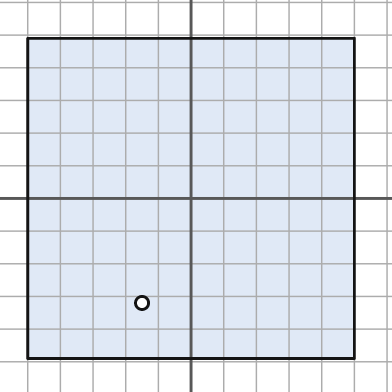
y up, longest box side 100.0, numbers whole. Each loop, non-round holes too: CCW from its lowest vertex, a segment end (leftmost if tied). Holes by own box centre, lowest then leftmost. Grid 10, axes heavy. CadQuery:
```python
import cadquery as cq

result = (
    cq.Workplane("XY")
    .moveTo(-50.0, -49.0)
    .lineTo(50.0, -49.0)
    .lineTo(50.0, 49.0)
    .lineTo(-50.0, 49.0)
    .close()
    .moveTo(-15.0, -32.0)
    .circle(2.0)
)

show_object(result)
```